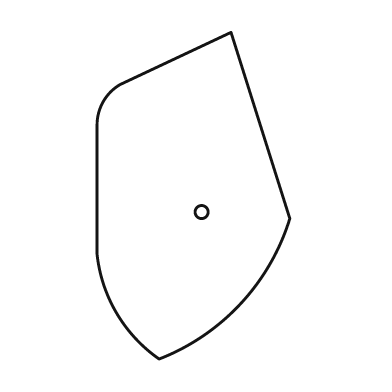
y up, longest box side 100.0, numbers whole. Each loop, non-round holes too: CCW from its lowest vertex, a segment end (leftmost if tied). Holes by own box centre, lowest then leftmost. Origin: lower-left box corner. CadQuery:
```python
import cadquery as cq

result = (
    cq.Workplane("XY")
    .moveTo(19.0, 0.0)
    .threePointArc((44.0, 17.0), (59.0, 43.0))
    .lineTo(41.0, 100.0)
    .lineTo(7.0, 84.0)
    .threePointArc((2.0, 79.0), (0.0, 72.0))
    .lineTo(0.0, 32.0)
    .threePointArc((6.0, 14.0), (19.0, 0.0))
    .close()
    .moveTo(32.0, 45.0)
    .circle(2.0)
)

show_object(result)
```